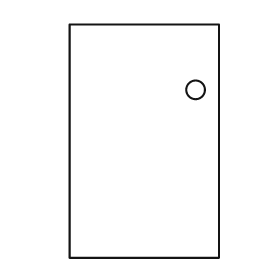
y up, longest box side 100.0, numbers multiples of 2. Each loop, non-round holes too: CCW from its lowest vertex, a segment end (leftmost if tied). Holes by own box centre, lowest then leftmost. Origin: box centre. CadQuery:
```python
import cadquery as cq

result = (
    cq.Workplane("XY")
    .moveTo(-32.0, -50.0)
    .lineTo(32.0, -50.0)
    .lineTo(32.0, 50.0)
    .lineTo(-32.0, 50.0)
    .close()
    .moveTo(22.0, 22.0)
    .circle(4.0)
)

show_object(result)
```